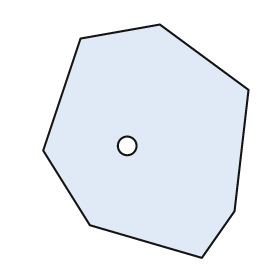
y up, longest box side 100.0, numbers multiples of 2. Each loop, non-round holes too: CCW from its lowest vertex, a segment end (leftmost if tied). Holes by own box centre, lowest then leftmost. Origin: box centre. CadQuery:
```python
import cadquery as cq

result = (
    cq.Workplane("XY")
    .moveTo(24.0, -50.0)
    .lineTo(38.0, -30.0)
    .lineTo(44.0, 22.0)
    .lineTo(6.0, 50.0)
    .lineTo(-28.0, 44.0)
    .lineTo(-44.0, -4.0)
    .lineTo(-24.0, -36.0)
    .close()
    .moveTo(-8.0, -2.0)
    .circle(4.0)
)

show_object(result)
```